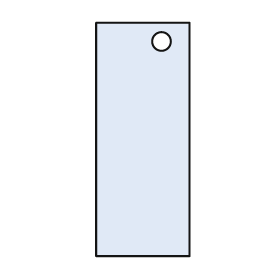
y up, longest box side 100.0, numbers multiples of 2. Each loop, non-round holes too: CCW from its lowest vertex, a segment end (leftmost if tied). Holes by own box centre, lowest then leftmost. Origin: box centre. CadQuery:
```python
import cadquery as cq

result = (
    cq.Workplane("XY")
    .moveTo(-20.0, -50.0)
    .lineTo(20.0, -50.0)
    .lineTo(20.0, 50.0)
    .lineTo(-20.0, 50.0)
    .close()
    .moveTo(8.0, 42.0)
    .circle(4.0)
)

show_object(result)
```